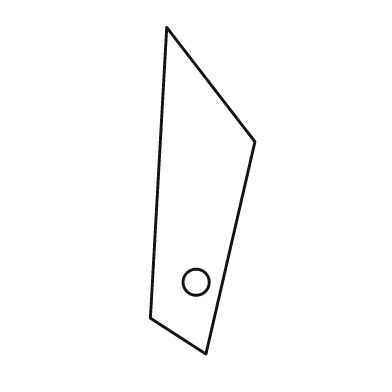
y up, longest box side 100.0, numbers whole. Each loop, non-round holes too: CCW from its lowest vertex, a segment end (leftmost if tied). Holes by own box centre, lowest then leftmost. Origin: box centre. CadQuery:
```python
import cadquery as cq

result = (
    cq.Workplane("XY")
    .moveTo(1.0, -50.0)
    .lineTo(16.0, 15.0)
    .lineTo(-11.0, 50.0)
    .lineTo(-16.0, -39.0)
    .close()
    .moveTo(-2.0, -28.0)
    .circle(4.0)
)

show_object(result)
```